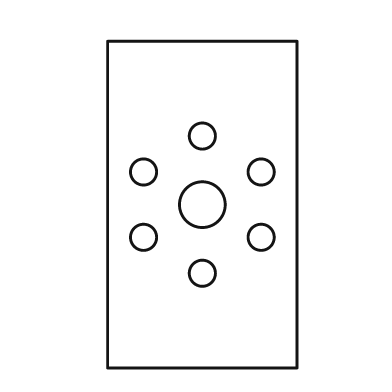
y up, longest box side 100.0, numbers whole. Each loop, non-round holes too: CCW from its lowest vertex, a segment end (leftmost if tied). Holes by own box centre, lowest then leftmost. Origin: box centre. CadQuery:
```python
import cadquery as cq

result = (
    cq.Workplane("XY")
    .moveTo(-29.0, -50.0)
    .lineTo(29.0, -50.0)
    .lineTo(29.0, 50.0)
    .lineTo(-29.0, 50.0)
    .close()
    .moveTo(0.0, -21.0)
    .circle(4.0)
    .moveTo(-18.0, -10.0)
    .circle(4.0)
    .moveTo(18.0, -10.0)
    .circle(4.0)
    .moveTo(0.0, 0.0)
    .circle(7.0)
    .moveTo(-18.0, 10.0)
    .circle(4.0)
    .moveTo(18.0, 10.0)
    .circle(4.0)
    .moveTo(0.0, 21.0)
    .circle(4.0)
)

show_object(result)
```